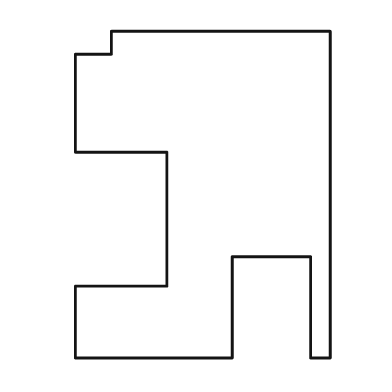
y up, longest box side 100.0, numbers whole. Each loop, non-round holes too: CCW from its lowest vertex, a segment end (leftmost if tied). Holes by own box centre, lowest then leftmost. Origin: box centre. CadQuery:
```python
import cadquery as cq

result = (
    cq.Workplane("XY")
    .moveTo(-39.0, -50.0)
    .lineTo(9.0, -50.0)
    .lineTo(9.0, -19.0)
    .lineTo(33.0, -19.0)
    .lineTo(33.0, -50.0)
    .lineTo(39.0, -50.0)
    .lineTo(39.0, 50.0)
    .lineTo(-28.0, 50.0)
    .lineTo(-28.0, 43.0)
    .lineTo(-39.0, 43.0)
    .lineTo(-39.0, 13.0)
    .lineTo(-11.0, 13.0)
    .lineTo(-11.0, -28.0)
    .lineTo(-39.0, -28.0)
    .close()
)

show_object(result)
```